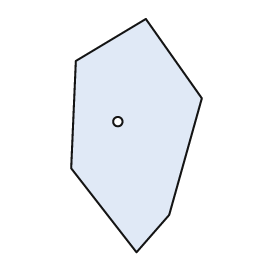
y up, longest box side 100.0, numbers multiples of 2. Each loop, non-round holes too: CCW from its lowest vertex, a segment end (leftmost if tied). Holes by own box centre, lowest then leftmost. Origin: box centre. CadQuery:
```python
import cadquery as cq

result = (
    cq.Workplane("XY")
    .moveTo(0.0, -50.0)
    .lineTo(14.0, -34.0)
    .lineTo(28.0, 16.0)
    .lineTo(4.0, 50.0)
    .lineTo(-26.0, 32.0)
    .lineTo(-28.0, -14.0)
    .close()
    .moveTo(-8.0, 6.0)
    .circle(2.0)
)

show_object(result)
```